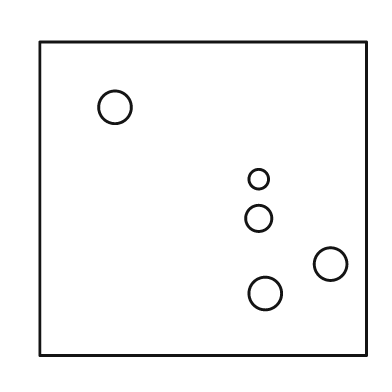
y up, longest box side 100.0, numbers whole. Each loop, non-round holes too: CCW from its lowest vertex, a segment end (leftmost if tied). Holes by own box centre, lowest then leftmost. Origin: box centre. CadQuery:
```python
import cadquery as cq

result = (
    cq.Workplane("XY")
    .moveTo(-50.0, -48.0)
    .lineTo(50.0, -48.0)
    .lineTo(50.0, 48.0)
    .lineTo(-50.0, 48.0)
    .close()
    .moveTo(19.0, -29.0)
    .circle(5.0)
    .moveTo(39.0, -20.0)
    .circle(5.0)
    .moveTo(17.0, -6.0)
    .circle(4.0)
    .moveTo(17.0, 6.0)
    .circle(3.0)
    .moveTo(-27.0, 28.0)
    .circle(5.0)
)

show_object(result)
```